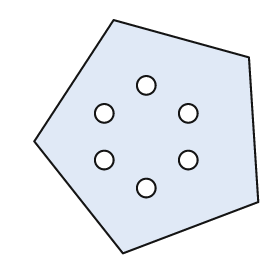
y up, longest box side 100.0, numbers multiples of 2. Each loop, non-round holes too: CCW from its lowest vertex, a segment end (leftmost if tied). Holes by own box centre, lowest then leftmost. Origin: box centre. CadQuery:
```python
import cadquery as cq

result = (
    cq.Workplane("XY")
    .moveTo(-10.0, -50.0)
    .lineTo(48.0, -28.0)
    .lineTo(44.0, 34.0)
    .lineTo(-14.0, 50.0)
    .lineTo(-48.0, -2.0)
    .close()
    .moveTo(0.0, -22.0)
    .circle(4.0)
    .moveTo(-18.0, -10.0)
    .circle(4.0)
    .moveTo(18.0, -10.0)
    .circle(4.0)
    .moveTo(-18.0, 10.0)
    .circle(4.0)
    .moveTo(18.0, 10.0)
    .circle(4.0)
    .moveTo(0.0, 22.0)
    .circle(4.0)
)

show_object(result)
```